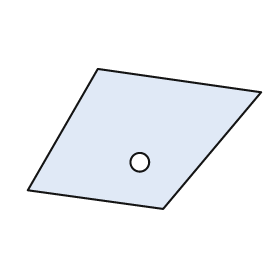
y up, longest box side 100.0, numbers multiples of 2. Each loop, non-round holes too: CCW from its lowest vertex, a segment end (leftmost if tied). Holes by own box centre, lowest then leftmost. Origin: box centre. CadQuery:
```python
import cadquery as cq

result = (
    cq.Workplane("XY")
    .moveTo(8.0, -30.0)
    .lineTo(50.0, 20.0)
    .lineTo(-20.0, 30.0)
    .lineTo(-50.0, -22.0)
    .close()
    .moveTo(-2.0, -10.0)
    .circle(4.0)
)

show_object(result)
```